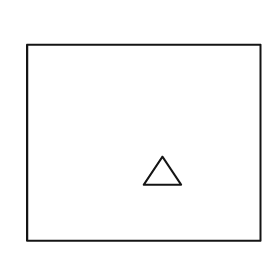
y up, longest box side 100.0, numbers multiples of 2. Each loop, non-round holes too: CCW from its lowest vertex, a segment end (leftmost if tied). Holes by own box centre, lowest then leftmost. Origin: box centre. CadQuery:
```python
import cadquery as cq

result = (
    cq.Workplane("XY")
    .moveTo(-50.0, -42.0)
    .lineTo(50.0, -42.0)
    .lineTo(50.0, 42.0)
    .lineTo(-50.0, 42.0)
    .close()
    .moveTo(0.0, -18.0)
    .lineTo(16.0, -18.0)
    .lineTo(8.0, -6.0)
    .close()
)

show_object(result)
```